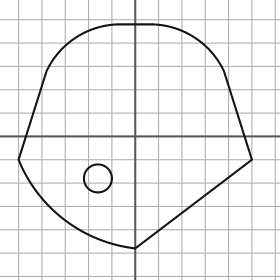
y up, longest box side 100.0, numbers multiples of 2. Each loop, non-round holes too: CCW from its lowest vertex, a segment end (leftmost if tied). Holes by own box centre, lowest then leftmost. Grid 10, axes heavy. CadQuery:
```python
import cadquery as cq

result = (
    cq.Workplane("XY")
    .moveTo(0.0, -48.0)
    .lineTo(50.0, -10.0)
    .lineTo(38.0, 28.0)
    .threePointArc((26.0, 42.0), (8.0, 48.0))
    .lineTo(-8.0, 48.0)
    .threePointArc((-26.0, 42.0), (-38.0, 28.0))
    .lineTo(-50.0, -10.0)
    .threePointArc((-30.0, -36.0), (0.0, -48.0))
    .close()
    .moveTo(-16.0, -18.0)
    .circle(6.0)
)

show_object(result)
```